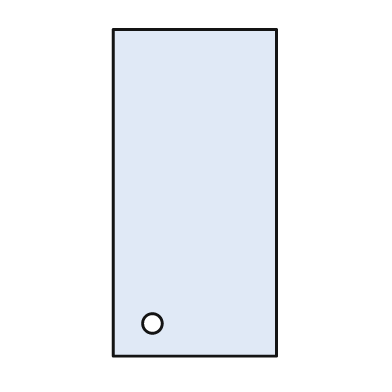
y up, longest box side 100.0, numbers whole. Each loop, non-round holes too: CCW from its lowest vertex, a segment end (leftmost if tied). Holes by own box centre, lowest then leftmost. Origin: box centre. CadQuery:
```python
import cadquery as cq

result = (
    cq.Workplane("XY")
    .moveTo(-25.0, -50.0)
    .lineTo(25.0, -50.0)
    .lineTo(25.0, 50.0)
    .lineTo(-25.0, 50.0)
    .close()
    .moveTo(-13.0, -40.0)
    .circle(3.0)
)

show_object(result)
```